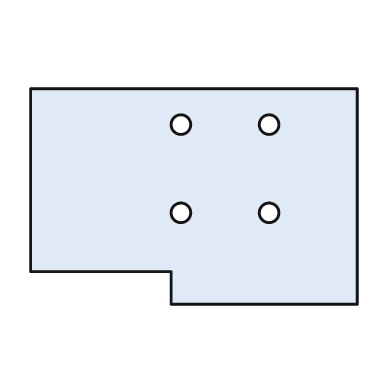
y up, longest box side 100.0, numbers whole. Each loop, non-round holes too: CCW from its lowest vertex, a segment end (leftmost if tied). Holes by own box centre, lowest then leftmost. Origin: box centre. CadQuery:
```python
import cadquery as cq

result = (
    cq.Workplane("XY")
    .moveTo(-7.0, -33.0)
    .lineTo(50.0, -33.0)
    .lineTo(50.0, 33.0)
    .lineTo(-50.0, 33.0)
    .lineTo(-50.0, -23.0)
    .lineTo(-7.0, -23.0)
    .close()
    .moveTo(-4.0, -5.0)
    .circle(3.0)
    .moveTo(23.0, -5.0)
    .circle(3.0)
    .moveTo(-4.0, 22.0)
    .circle(3.0)
    .moveTo(23.0, 22.0)
    .circle(3.0)
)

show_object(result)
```